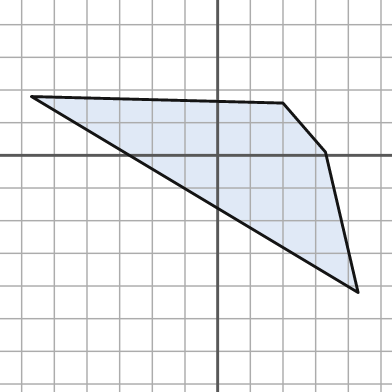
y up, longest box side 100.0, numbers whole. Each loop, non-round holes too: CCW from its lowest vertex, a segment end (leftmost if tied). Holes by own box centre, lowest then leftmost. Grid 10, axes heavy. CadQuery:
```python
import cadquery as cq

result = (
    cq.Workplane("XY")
    .moveTo(43.0, -42.0)
    .lineTo(33.0, 1.0)
    .lineTo(20.0, 16.0)
    .lineTo(-57.0, 18.0)
    .close()
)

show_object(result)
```